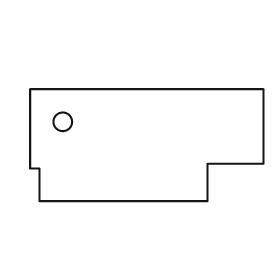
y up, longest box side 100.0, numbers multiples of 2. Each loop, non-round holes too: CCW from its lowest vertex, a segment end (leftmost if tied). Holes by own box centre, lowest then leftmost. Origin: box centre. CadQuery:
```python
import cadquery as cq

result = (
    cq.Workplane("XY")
    .moveTo(-46.0, -24.0)
    .lineTo(26.0, -24.0)
    .lineTo(26.0, -8.0)
    .lineTo(50.0, -8.0)
    .lineTo(50.0, 24.0)
    .lineTo(-50.0, 24.0)
    .lineTo(-50.0, -10.0)
    .lineTo(-46.0, -10.0)
    .close()
    .moveTo(-36.0, 10.0)
    .circle(4.0)
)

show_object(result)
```